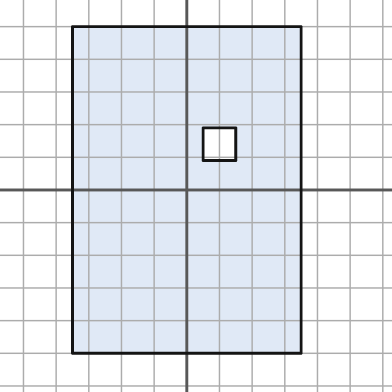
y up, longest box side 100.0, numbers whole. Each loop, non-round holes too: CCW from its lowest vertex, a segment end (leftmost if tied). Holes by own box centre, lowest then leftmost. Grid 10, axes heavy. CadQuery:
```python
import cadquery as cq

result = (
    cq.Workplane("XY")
    .moveTo(-35.0, -50.0)
    .lineTo(35.0, -50.0)
    .lineTo(35.0, 50.0)
    .lineTo(-35.0, 50.0)
    .close()
    .moveTo(5.0, 9.0)
    .lineTo(15.0, 9.0)
    .lineTo(15.0, 19.0)
    .lineTo(5.0, 19.0)
    .close()
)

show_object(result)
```